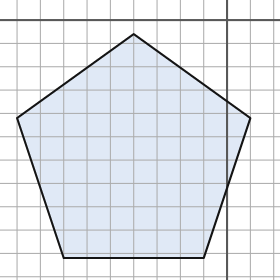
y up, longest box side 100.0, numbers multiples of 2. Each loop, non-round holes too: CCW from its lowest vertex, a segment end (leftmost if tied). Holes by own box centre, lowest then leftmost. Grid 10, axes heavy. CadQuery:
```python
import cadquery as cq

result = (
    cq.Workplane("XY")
    .moveTo(-70.0, -102.0)
    .lineTo(-10.0, -102.0)
    .lineTo(10.0, -42.0)
    .lineTo(-40.0, -6.0)
    .lineTo(-90.0, -42.0)
    .close()
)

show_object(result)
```